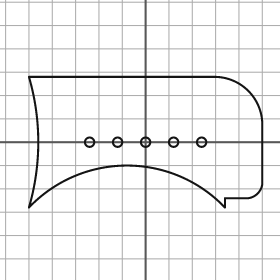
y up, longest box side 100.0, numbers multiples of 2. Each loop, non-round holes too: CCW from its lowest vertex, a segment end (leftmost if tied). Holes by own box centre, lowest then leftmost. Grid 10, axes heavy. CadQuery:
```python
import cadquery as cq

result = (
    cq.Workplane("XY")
    .moveTo(-50.0, -28.0)
    .threePointArc((-8.0, -10.0), (34.0, -28.0))
    .lineTo(34.0, -24.0)
    .lineTo(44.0, -24.0)
    .threePointArc((48.0, -22.0), (50.0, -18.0))
    .lineTo(50.0, 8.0)
    .threePointArc((44.0, 22.0), (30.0, 28.0))
    .lineTo(-50.0, 28.0)
    .threePointArc((-46.0, 0.0), (-50.0, -28.0))
    .close()
    .moveTo(-24.0, 0.0)
    .circle(2.0)
    .moveTo(-12.0, 0.0)
    .circle(2.0)
    .moveTo(0.0, 0.0)
    .circle(2.0)
    .moveTo(12.0, 0.0)
    .circle(2.0)
    .moveTo(24.0, 0.0)
    .circle(2.0)
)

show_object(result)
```